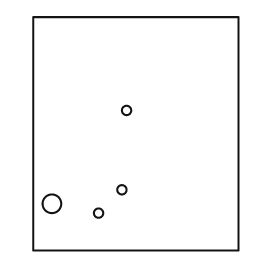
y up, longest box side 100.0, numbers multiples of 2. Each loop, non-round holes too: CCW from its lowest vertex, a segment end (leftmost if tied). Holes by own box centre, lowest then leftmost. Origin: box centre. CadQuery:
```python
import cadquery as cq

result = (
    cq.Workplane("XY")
    .moveTo(-44.0, -50.0)
    .lineTo(44.0, -50.0)
    .lineTo(44.0, 50.0)
    .lineTo(-44.0, 50.0)
    .close()
    .moveTo(-16.0, -34.0)
    .circle(2.0)
    .moveTo(-36.0, -30.0)
    .circle(4.0)
    .moveTo(-6.0, -24.0)
    .circle(2.0)
    .moveTo(-4.0, 10.0)
    .circle(2.0)
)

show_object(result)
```